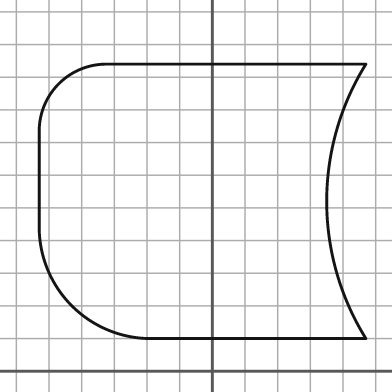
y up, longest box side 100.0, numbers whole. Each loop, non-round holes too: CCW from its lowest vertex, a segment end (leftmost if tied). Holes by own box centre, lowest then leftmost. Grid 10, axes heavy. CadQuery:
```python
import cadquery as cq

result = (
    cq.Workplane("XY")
    .moveTo(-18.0, 10.0)
    .lineTo(47.0, 10.0)
    .threePointArc((35.0, 52.0), (47.0, 94.0))
    .lineTo(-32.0, 94.0)
    .threePointArc((-47.0, 88.0), (-53.0, 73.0))
    .lineTo(-53.0, 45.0)
    .threePointArc((-43.0, 20.0), (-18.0, 10.0))
    .close()
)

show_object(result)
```